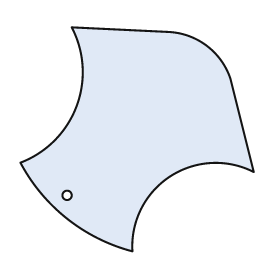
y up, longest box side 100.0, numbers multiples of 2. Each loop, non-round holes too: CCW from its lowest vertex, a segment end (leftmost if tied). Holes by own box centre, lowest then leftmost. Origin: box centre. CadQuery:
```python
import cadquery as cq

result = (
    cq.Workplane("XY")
    .moveTo(-2.0, -48.0)
    .threePointArc((14.0, -16.0), (50.0, -14.0))
    .lineTo(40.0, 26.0)
    .threePointArc((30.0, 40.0), (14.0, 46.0))
    .lineTo(-28.0, 48.0)
    .threePointArc((-26.0, 14.0), (-50.0, -10.0))
    .threePointArc((-30.0, -34.0), (-2.0, -48.0))
    .close()
    .moveTo(-30.0, -24.0)
    .circle(2.0)
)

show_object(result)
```